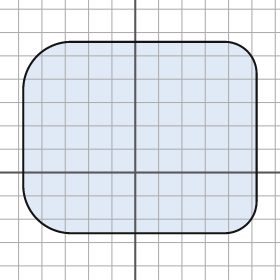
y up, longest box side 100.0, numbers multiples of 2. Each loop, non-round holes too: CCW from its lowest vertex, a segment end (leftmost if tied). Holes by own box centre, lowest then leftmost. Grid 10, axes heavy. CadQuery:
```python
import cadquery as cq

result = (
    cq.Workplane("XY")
    .moveTo(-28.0, -26.0)
    .lineTo(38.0, -26.0)
    .threePointArc((48.0, -22.0), (52.0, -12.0))
    .lineTo(52.0, 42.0)
    .threePointArc((48.0, 52.0), (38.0, 56.0))
    .lineTo(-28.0, 56.0)
    .threePointArc((-42.0, 50.0), (-48.0, 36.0))
    .lineTo(-48.0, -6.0)
    .threePointArc((-42.0, -20.0), (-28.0, -26.0))
    .close()
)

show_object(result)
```